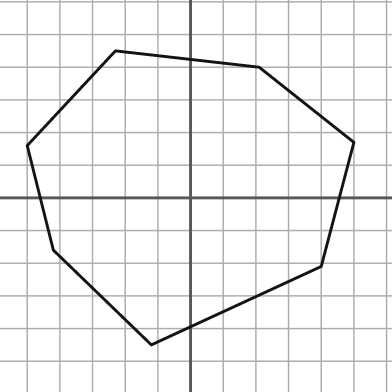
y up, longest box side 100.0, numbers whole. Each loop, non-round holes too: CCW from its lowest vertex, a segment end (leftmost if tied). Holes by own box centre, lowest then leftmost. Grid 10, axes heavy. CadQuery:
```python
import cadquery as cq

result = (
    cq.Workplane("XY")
    .moveTo(-12.0, -45.0)
    .lineTo(40.0, -21.0)
    .lineTo(50.0, 17.0)
    .lineTo(21.0, 40.0)
    .lineTo(-23.0, 45.0)
    .lineTo(-50.0, 16.0)
    .lineTo(-42.0, -16.0)
    .close()
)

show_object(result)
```